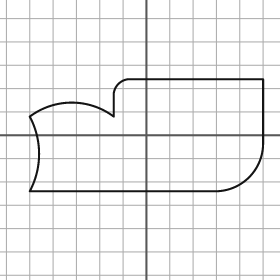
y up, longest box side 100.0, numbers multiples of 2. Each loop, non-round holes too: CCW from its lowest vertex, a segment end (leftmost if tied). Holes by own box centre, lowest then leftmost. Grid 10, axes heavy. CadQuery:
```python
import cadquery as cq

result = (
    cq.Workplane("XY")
    .moveTo(-50.0, -24.0)
    .lineTo(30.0, -24.0)
    .threePointArc((44.0, -18.0), (50.0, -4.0))
    .lineTo(50.0, 24.0)
    .lineTo(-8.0, 24.0)
    .threePointArc((-12.0, 22.0), (-14.0, 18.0))
    .lineTo(-14.0, 8.0)
    .threePointArc((-32.0, 14.0), (-50.0, 8.0))
    .threePointArc((-46.0, -8.0), (-50.0, -24.0))
    .close()
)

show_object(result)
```